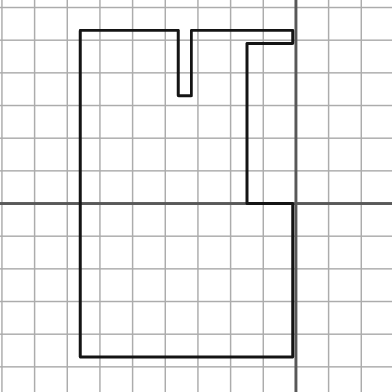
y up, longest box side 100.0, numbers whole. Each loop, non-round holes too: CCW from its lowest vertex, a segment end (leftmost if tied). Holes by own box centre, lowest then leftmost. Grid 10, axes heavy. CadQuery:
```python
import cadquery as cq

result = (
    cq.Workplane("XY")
    .moveTo(-66.0, -47.0)
    .lineTo(-1.0, -47.0)
    .lineTo(-1.0, 0.0)
    .lineTo(-15.0, 0.0)
    .lineTo(-15.0, 49.0)
    .lineTo(-1.0, 49.0)
    .lineTo(-1.0, 53.0)
    .lineTo(-32.0, 53.0)
    .lineTo(-32.0, 33.0)
    .lineTo(-36.0, 33.0)
    .lineTo(-36.0, 53.0)
    .lineTo(-66.0, 53.0)
    .close()
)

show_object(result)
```